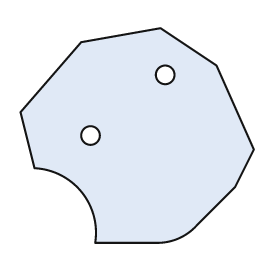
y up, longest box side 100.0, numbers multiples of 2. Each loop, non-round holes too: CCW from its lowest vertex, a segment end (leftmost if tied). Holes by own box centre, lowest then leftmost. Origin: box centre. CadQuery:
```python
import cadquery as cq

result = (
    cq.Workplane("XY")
    .moveTo(-18.0, -46.0)
    .lineTo(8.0, -46.0)
    .threePointArc((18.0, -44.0), (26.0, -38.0))
    .lineTo(42.0, -22.0)
    .lineTo(50.0, -6.0)
    .lineTo(34.0, 30.0)
    .lineTo(10.0, 46.0)
    .lineTo(-24.0, 40.0)
    .lineTo(-50.0, 10.0)
    .lineTo(-44.0, -14.0)
    .threePointArc((-24.0, -24.0), (-18.0, -46.0))
    .close()
    .moveTo(-20.0, 0.0)
    .circle(4.0)
    .moveTo(12.0, 26.0)
    .circle(4.0)
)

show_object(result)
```